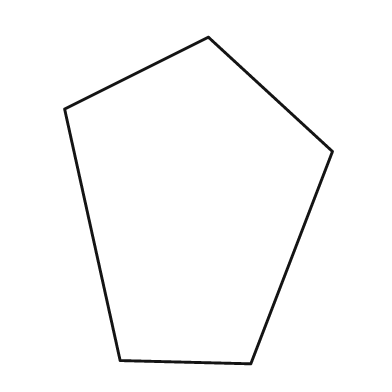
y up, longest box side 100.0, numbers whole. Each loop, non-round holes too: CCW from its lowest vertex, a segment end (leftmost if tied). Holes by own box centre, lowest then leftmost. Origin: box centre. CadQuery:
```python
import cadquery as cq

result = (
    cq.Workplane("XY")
    .moveTo(16.0, -50.0)
    .lineTo(41.0, 15.0)
    .lineTo(3.0, 50.0)
    .lineTo(-41.0, 28.0)
    .lineTo(-24.0, -49.0)
    .close()
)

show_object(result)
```